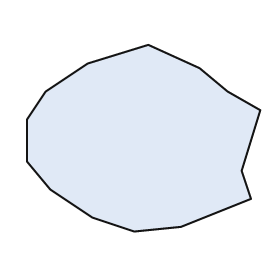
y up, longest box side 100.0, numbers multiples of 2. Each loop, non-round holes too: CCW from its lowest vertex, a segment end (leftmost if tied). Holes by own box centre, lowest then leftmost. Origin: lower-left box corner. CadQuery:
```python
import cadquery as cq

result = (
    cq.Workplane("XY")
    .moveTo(46.0, 0.0)
    .lineTo(66.0, 2.0)
    .lineTo(96.0, 14.0)
    .lineTo(92.0, 26.0)
    .lineTo(100.0, 52.0)
    .lineTo(86.0, 60.0)
    .lineTo(74.0, 70.0)
    .lineTo(52.0, 80.0)
    .lineTo(26.0, 72.0)
    .lineTo(8.0, 60.0)
    .lineTo(0.0, 48.0)
    .lineTo(0.0, 30.0)
    .lineTo(10.0, 18.0)
    .lineTo(28.0, 6.0)
    .close()
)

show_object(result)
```